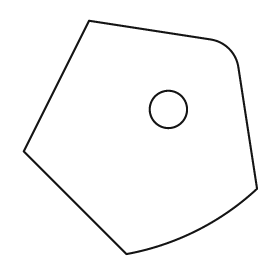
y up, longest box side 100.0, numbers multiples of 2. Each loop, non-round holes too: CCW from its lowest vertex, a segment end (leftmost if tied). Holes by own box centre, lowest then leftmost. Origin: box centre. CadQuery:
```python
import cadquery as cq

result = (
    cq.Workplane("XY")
    .moveTo(-6.0, -50.0)
    .threePointArc((24.0, -40.0), (50.0, -22.0))
    .lineTo(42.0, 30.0)
    .threePointArc((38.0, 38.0), (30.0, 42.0))
    .lineTo(-22.0, 50.0)
    .lineTo(-50.0, -6.0)
    .close()
    .moveTo(12.0, 12.0)
    .circle(8.0)
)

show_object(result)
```